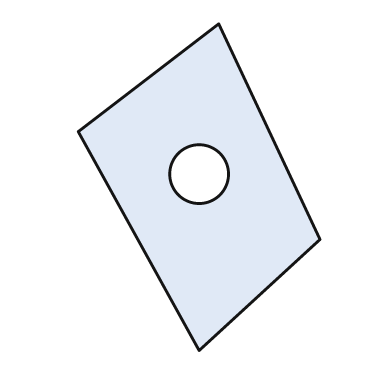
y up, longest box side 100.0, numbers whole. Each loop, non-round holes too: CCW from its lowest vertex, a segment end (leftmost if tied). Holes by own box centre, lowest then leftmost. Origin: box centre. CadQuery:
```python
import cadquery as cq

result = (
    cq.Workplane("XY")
    .moveTo(0.0, -50.0)
    .lineTo(37.0, -16.0)
    .lineTo(6.0, 50.0)
    .lineTo(-37.0, 17.0)
    .close()
    .moveTo(0.0, 4.0)
    .circle(9.0)
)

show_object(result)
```